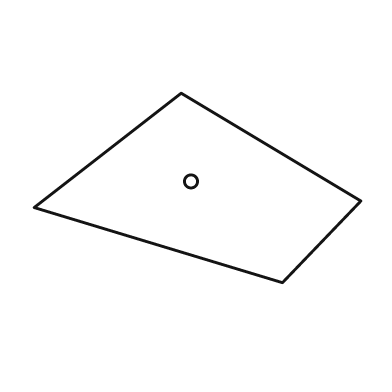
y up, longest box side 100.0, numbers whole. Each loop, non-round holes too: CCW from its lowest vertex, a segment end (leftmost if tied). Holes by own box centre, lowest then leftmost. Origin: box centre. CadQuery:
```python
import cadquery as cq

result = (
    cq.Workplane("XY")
    .moveTo(26.0, -29.0)
    .lineTo(50.0, -4.0)
    .lineTo(-5.0, 29.0)
    .lineTo(-50.0, -6.0)
    .close()
    .moveTo(-2.0, 2.0)
    .circle(2.0)
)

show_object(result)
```